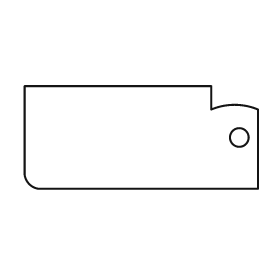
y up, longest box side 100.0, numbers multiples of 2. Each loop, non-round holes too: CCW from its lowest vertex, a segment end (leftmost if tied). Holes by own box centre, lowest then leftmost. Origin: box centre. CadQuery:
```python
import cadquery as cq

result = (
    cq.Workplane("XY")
    .moveTo(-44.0, -22.0)
    .lineTo(50.0, -22.0)
    .lineTo(50.0, 12.0)
    .threePointArc((40.0, 14.0), (30.0, 12.0))
    .lineTo(30.0, 22.0)
    .lineTo(-50.0, 22.0)
    .lineTo(-50.0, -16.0)
    .threePointArc((-48.0, -20.0), (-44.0, -22.0))
    .close()
    .moveTo(42.0, 0.0)
    .circle(4.0)
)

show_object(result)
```